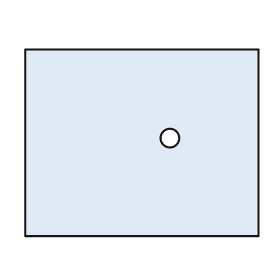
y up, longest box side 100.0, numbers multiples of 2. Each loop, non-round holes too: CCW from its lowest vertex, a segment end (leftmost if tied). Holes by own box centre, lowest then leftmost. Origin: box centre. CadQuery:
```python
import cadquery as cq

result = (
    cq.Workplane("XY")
    .moveTo(-50.0, -40.0)
    .lineTo(50.0, -40.0)
    .lineTo(50.0, 40.0)
    .lineTo(-50.0, 40.0)
    .close()
    .moveTo(12.0, 2.0)
    .circle(4.0)
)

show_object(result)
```